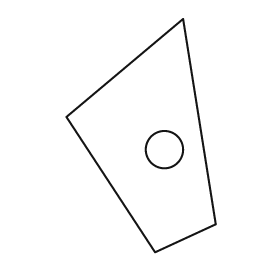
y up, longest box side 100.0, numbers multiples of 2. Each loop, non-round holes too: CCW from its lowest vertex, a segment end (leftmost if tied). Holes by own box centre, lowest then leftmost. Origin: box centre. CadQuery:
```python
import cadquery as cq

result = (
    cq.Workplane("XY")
    .moveTo(6.0, -50.0)
    .lineTo(32.0, -38.0)
    .lineTo(18.0, 50.0)
    .lineTo(-32.0, 8.0)
    .close()
    .moveTo(10.0, -6.0)
    .circle(8.0)
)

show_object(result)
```